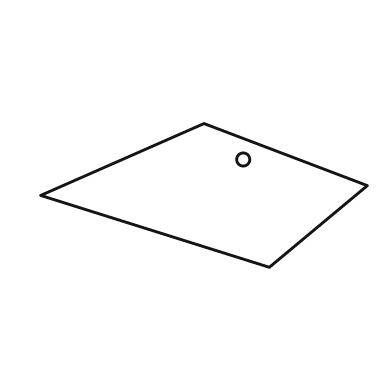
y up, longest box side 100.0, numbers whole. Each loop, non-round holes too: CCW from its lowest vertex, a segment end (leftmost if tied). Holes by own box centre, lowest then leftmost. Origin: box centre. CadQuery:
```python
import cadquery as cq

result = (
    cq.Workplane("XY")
    .moveTo(20.0, -22.0)
    .lineTo(50.0, 3.0)
    .lineTo(0.0, 22.0)
    .lineTo(-50.0, 0.0)
    .close()
    .moveTo(12.0, 11.0)
    .circle(2.0)
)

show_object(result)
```